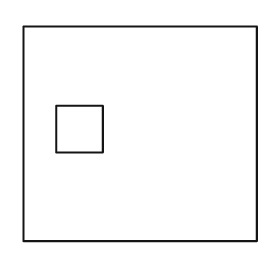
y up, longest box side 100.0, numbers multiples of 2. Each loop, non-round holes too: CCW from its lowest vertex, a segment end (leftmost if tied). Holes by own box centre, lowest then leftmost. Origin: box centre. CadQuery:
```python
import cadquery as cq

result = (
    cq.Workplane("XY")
    .moveTo(-50.0, -46.0)
    .lineTo(50.0, -46.0)
    .lineTo(50.0, 46.0)
    .lineTo(-50.0, 46.0)
    .close()
    .moveTo(-36.0, -8.0)
    .lineTo(-16.0, -8.0)
    .lineTo(-16.0, 12.0)
    .lineTo(-36.0, 12.0)
    .close()
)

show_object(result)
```